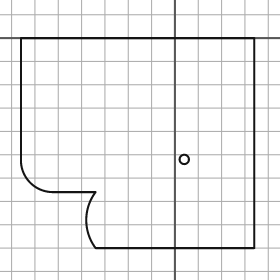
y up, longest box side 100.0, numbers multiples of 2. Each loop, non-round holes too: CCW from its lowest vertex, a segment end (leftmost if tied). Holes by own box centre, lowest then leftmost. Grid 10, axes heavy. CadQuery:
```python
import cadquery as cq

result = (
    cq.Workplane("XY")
    .moveTo(-34.0, -90.0)
    .lineTo(34.0, -90.0)
    .lineTo(34.0, 0.0)
    .lineTo(-66.0, 0.0)
    .lineTo(-66.0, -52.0)
    .threePointArc((-62.0, -62.0), (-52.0, -66.0))
    .lineTo(-34.0, -66.0)
    .threePointArc((-38.0, -78.0), (-34.0, -90.0))
    .close()
    .moveTo(4.0, -52.0)
    .circle(2.0)
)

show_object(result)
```